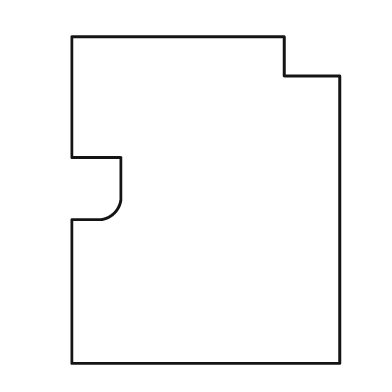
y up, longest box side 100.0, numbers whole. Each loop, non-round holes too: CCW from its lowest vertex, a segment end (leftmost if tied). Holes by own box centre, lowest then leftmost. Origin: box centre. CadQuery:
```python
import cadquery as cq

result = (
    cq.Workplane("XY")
    .moveTo(-41.0, -50.0)
    .lineTo(41.0, -50.0)
    .lineTo(41.0, 38.0)
    .lineTo(24.0, 38.0)
    .lineTo(24.0, 50.0)
    .lineTo(-41.0, 50.0)
    .lineTo(-41.0, 13.0)
    .lineTo(-26.0, 13.0)
    .lineTo(-26.0, 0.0)
    .threePointArc((-28.0, -4.0), (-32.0, -6.0))
    .lineTo(-41.0, -6.0)
    .close()
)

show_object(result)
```